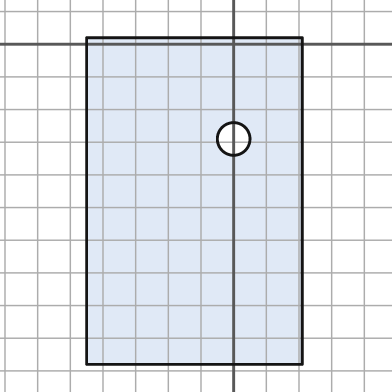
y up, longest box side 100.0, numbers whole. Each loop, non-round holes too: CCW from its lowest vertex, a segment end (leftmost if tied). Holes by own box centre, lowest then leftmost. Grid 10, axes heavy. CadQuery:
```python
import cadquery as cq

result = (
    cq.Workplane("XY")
    .moveTo(-45.0, -98.0)
    .lineTo(21.0, -98.0)
    .lineTo(21.0, 2.0)
    .lineTo(-45.0, 2.0)
    .close()
    .moveTo(0.0, -29.0)
    .circle(5.0)
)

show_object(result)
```